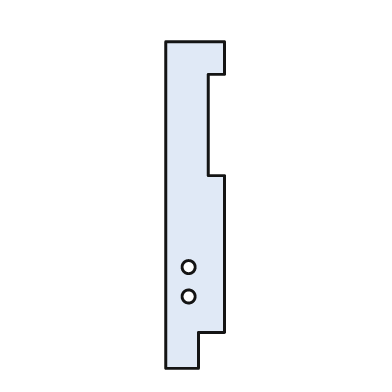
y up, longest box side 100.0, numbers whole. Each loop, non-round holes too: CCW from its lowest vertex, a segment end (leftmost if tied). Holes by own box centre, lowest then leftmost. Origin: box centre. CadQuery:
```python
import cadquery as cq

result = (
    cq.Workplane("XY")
    .moveTo(-9.0, -50.0)
    .lineTo(1.0, -50.0)
    .lineTo(1.0, -39.0)
    .lineTo(9.0, -39.0)
    .lineTo(9.0, 9.0)
    .lineTo(4.0, 9.0)
    .lineTo(4.0, 40.0)
    .lineTo(9.0, 40.0)
    .lineTo(9.0, 50.0)
    .lineTo(-9.0, 50.0)
    .close()
    .moveTo(-2.0, -28.0)
    .circle(2.0)
    .moveTo(-2.0, -19.0)
    .circle(2.0)
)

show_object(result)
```